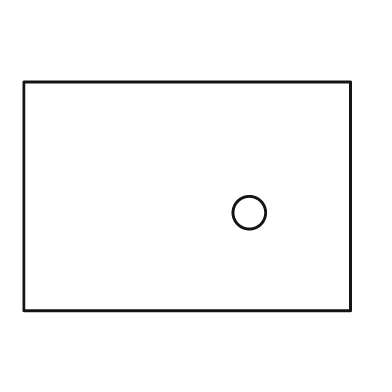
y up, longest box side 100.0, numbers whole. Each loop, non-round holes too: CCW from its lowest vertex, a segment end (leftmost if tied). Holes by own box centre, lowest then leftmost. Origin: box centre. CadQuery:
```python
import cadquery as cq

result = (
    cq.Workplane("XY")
    .moveTo(-50.0, -35.0)
    .lineTo(50.0, -35.0)
    .lineTo(50.0, 35.0)
    .lineTo(-50.0, 35.0)
    .close()
    .moveTo(19.0, -5.0)
    .circle(5.0)
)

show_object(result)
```